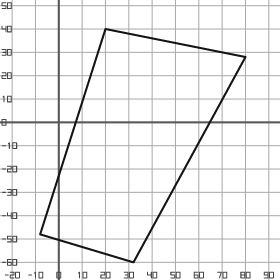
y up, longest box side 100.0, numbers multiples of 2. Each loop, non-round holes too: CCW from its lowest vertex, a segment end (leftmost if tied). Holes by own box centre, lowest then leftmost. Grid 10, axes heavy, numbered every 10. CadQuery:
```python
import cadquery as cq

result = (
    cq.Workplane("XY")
    .moveTo(32.0, -60.0)
    .lineTo(80.0, 28.0)
    .lineTo(20.0, 40.0)
    .lineTo(-8.0, -48.0)
    .close()
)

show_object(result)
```